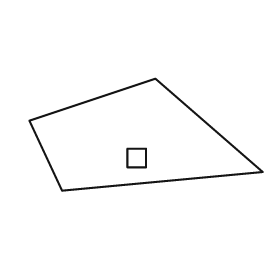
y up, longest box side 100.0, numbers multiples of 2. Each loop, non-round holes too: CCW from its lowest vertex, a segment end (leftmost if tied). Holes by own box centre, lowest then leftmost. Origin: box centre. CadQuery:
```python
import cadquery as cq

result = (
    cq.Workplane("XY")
    .moveTo(-36.0, -24.0)
    .lineTo(50.0, -16.0)
    .lineTo(4.0, 24.0)
    .lineTo(-50.0, 6.0)
    .close()
    .moveTo(-8.0, -14.0)
    .lineTo(0.0, -14.0)
    .lineTo(0.0, -6.0)
    .lineTo(-8.0, -6.0)
    .close()
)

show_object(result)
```